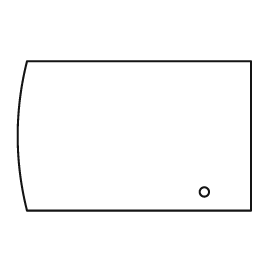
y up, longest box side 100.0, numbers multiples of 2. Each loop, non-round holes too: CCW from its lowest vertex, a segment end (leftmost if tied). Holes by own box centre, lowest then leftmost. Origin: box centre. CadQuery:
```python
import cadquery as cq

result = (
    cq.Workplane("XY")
    .moveTo(-46.0, -32.0)
    .lineTo(50.0, -32.0)
    .lineTo(50.0, 32.0)
    .lineTo(-46.0, 32.0)
    .threePointArc((-50.0, 0.0), (-46.0, -32.0))
    .close()
    .moveTo(30.0, -24.0)
    .circle(2.0)
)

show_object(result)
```